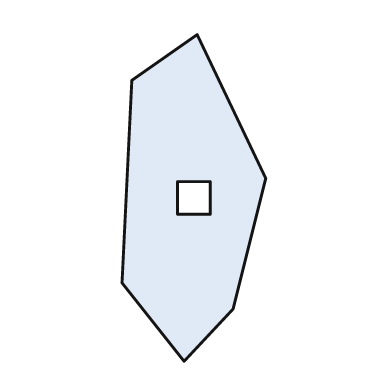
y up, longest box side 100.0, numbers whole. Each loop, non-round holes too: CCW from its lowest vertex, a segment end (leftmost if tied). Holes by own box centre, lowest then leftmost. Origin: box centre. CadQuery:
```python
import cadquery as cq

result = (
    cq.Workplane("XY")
    .moveTo(-3.0, -50.0)
    .lineTo(12.0, -34.0)
    .lineTo(22.0, 6.0)
    .lineTo(1.0, 50.0)
    .lineTo(-19.0, 36.0)
    .lineTo(-22.0, -26.0)
    .close()
    .moveTo(-5.0, -5.0)
    .lineTo(5.0, -5.0)
    .lineTo(5.0, 5.0)
    .lineTo(-5.0, 5.0)
    .close()
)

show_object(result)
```